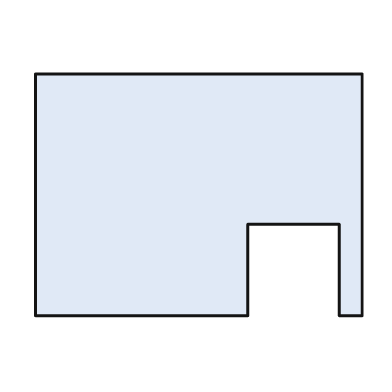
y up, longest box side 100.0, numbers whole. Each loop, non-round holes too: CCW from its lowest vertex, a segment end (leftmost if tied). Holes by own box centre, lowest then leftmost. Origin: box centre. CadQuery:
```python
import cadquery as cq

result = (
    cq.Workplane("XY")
    .moveTo(-50.0, -37.0)
    .lineTo(15.0, -37.0)
    .lineTo(15.0, -9.0)
    .lineTo(43.0, -9.0)
    .lineTo(43.0, -37.0)
    .lineTo(50.0, -37.0)
    .lineTo(50.0, 37.0)
    .lineTo(-50.0, 37.0)
    .close()
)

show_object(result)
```